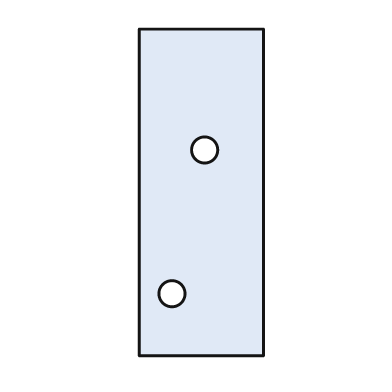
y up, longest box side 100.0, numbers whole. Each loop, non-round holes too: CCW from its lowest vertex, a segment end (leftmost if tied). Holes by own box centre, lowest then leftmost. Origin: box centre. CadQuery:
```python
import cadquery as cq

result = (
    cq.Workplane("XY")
    .moveTo(-19.0, -50.0)
    .lineTo(19.0, -50.0)
    .lineTo(19.0, 50.0)
    .lineTo(-19.0, 50.0)
    .close()
    .moveTo(-9.0, -31.0)
    .circle(4.0)
    .moveTo(1.0, 13.0)
    .circle(4.0)
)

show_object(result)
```